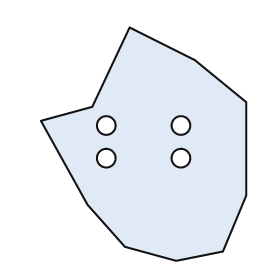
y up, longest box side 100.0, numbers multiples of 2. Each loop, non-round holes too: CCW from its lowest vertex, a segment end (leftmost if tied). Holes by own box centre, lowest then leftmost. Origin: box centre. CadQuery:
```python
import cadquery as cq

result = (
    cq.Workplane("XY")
    .moveTo(14.0, -50.0)
    .lineTo(34.0, -46.0)
    .lineTo(44.0, -22.0)
    .lineTo(44.0, 18.0)
    .lineTo(22.0, 36.0)
    .lineTo(-6.0, 50.0)
    .lineTo(-22.0, 16.0)
    .lineTo(-44.0, 10.0)
    .lineTo(-24.0, -26.0)
    .lineTo(-8.0, -44.0)
    .close()
    .moveTo(-16.0, -6.0)
    .circle(4.0)
    .moveTo(16.0, -6.0)
    .circle(4.0)
    .moveTo(-16.0, 8.0)
    .circle(4.0)
    .moveTo(16.0, 8.0)
    .circle(4.0)
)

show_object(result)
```